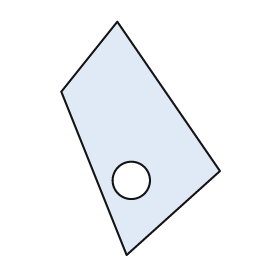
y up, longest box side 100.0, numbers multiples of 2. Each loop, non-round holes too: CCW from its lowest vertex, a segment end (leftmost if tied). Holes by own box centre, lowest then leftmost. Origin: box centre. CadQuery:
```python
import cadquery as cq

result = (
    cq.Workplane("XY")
    .moveTo(-6.0, -50.0)
    .lineTo(34.0, -14.0)
    .lineTo(-10.0, 50.0)
    .lineTo(-34.0, 20.0)
    .close()
    .moveTo(-4.0, -18.0)
    .circle(8.0)
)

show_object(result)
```